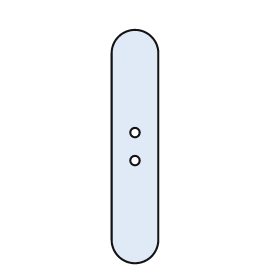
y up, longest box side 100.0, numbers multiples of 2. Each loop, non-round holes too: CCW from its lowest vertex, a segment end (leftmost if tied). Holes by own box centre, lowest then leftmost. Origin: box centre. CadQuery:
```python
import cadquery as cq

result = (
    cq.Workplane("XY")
    .moveTo(-10.0, -40.0)
    .threePointArc((0.0, -50.0), (10.0, -40.0))
    .lineTo(10.0, 40.0)
    .threePointArc((0.0, 50.0), (-10.0, 40.0))
    .close()
    .moveTo(0.0, -6.0)
    .circle(2.0)
    .moveTo(0.0, 6.0)
    .circle(2.0)
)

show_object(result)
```